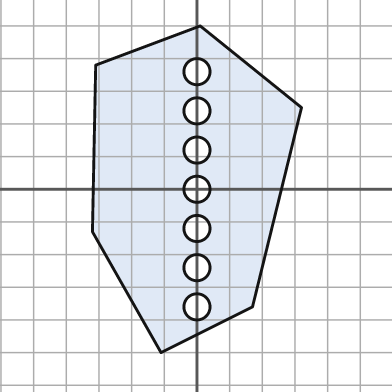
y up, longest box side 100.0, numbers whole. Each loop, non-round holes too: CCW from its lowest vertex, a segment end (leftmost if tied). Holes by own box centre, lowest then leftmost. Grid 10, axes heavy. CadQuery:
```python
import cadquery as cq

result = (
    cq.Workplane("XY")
    .moveTo(-11.0, -50.0)
    .lineTo(17.0, -36.0)
    .lineTo(32.0, 25.0)
    .lineTo(1.0, 50.0)
    .lineTo(-31.0, 38.0)
    .lineTo(-32.0, -13.0)
    .close()
    .moveTo(0.0, -36.0)
    .circle(4.0)
    .moveTo(0.0, -24.0)
    .circle(4.0)
    .moveTo(0.0, -12.0)
    .circle(4.0)
    .moveTo(0.0, 0.0)
    .circle(4.0)
    .moveTo(0.0, 12.0)
    .circle(4.0)
    .moveTo(0.0, 24.0)
    .circle(4.0)
    .moveTo(0.0, 36.0)
    .circle(4.0)
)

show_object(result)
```